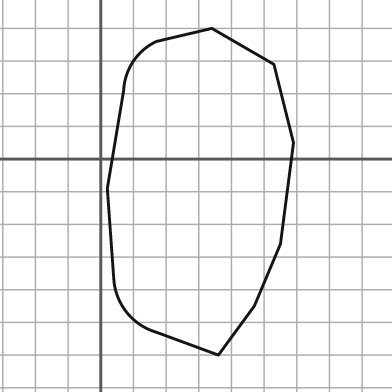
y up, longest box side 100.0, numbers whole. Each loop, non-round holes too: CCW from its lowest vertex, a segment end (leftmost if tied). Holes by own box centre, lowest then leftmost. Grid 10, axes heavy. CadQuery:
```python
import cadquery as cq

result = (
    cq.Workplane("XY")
    .moveTo(36.0, -60.0)
    .lineTo(47.0, -45.0)
    .lineTo(55.0, -26.0)
    .lineTo(59.0, 5.0)
    .lineTo(53.0, 29.0)
    .lineTo(34.0, 40.0)
    .lineTo(17.0, 36.0)
    .threePointArc((10.0, 30.0), (7.0, 21.0))
    .lineTo(2.0, -9.0)
    .lineTo(4.0, -37.0)
    .threePointArc((8.0, -47.0), (17.0, -53.0))
    .close()
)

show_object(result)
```